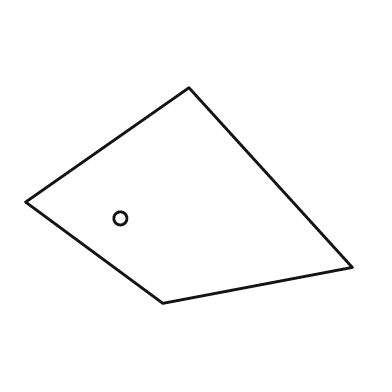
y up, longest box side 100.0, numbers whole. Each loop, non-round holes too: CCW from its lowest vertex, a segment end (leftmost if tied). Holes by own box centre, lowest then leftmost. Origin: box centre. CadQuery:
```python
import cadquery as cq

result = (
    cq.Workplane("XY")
    .moveTo(-8.0, -33.0)
    .lineTo(50.0, -22.0)
    .lineTo(0.0, 33.0)
    .lineTo(-50.0, -2.0)
    .close()
    .moveTo(-21.0, -7.0)
    .circle(2.0)
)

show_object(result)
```